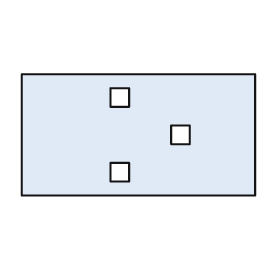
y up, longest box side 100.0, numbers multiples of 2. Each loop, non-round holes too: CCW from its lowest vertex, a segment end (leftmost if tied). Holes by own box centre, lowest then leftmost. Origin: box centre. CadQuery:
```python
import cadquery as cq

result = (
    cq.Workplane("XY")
    .moveTo(-50.0, -26.0)
    .lineTo(50.0, -26.0)
    .lineTo(50.0, 26.0)
    .lineTo(-50.0, 26.0)
    .close()
    .moveTo(-12.0, -20.0)
    .lineTo(-4.0, -20.0)
    .lineTo(-4.0, -12.0)
    .lineTo(-12.0, -12.0)
    .close()
    .moveTo(14.0, -4.0)
    .lineTo(22.0, -4.0)
    .lineTo(22.0, 4.0)
    .lineTo(14.0, 4.0)
    .close()
    .moveTo(-12.0, 12.0)
    .lineTo(-4.0, 12.0)
    .lineTo(-4.0, 20.0)
    .lineTo(-12.0, 20.0)
    .close()
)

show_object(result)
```